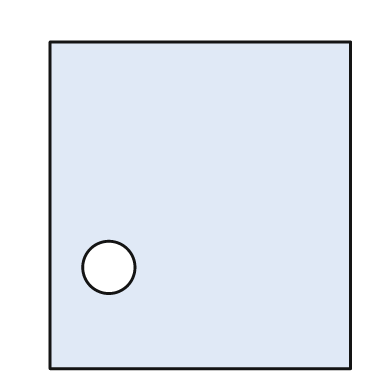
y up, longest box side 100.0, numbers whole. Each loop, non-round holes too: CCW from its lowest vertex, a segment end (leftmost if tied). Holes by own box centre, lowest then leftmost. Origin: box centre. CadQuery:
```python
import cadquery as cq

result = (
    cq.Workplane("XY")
    .moveTo(-46.0, -50.0)
    .lineTo(46.0, -50.0)
    .lineTo(46.0, 50.0)
    .lineTo(-46.0, 50.0)
    .close()
    .moveTo(-28.0, -19.0)
    .circle(8.0)
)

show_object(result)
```